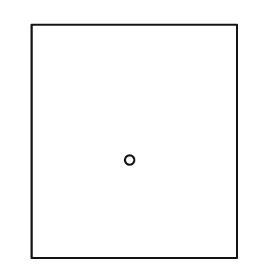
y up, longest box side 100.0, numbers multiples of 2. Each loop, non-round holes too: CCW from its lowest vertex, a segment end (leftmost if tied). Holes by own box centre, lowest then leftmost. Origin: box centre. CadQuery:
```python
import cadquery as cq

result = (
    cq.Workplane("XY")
    .moveTo(-44.0, -50.0)
    .lineTo(44.0, -50.0)
    .lineTo(44.0, 50.0)
    .lineTo(-44.0, 50.0)
    .close()
    .moveTo(-2.0, -8.0)
    .circle(2.0)
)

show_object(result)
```